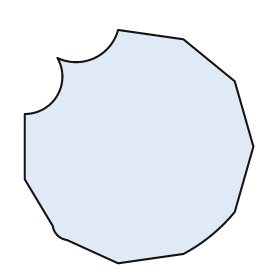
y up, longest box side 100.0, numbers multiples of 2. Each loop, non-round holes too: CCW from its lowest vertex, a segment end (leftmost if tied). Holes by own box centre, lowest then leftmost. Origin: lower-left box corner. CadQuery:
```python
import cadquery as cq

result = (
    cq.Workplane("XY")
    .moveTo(40.0, 0.0)
    .lineTo(68.0, 4.0)
    .threePointArc((80.0, 12.0), (90.0, 22.0))
    .lineTo(98.0, 50.0)
    .lineTo(90.0, 78.0)
    .lineTo(68.0, 96.0)
    .lineTo(40.0, 100.0)
    .threePointArc((30.0, 88.0), (14.0, 88.0))
    .threePointArc((14.0, 72.0), (0.0, 64.0))
    .lineTo(0.0, 36.0)
    .lineTo(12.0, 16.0)
    .threePointArc((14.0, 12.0), (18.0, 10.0))
    .close()
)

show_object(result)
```